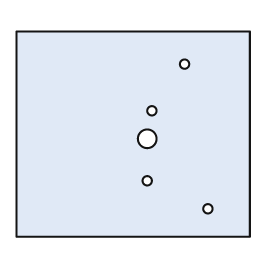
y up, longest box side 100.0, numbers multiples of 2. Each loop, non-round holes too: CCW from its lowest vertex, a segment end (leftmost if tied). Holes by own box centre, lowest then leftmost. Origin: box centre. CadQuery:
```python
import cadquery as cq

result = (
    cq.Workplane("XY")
    .moveTo(-50.0, -44.0)
    .lineTo(50.0, -44.0)
    .lineTo(50.0, 44.0)
    .lineTo(-50.0, 44.0)
    .close()
    .moveTo(32.0, -32.0)
    .circle(2.0)
    .moveTo(6.0, -20.0)
    .circle(2.0)
    .moveTo(6.0, -2.0)
    .circle(4.0)
    .moveTo(8.0, 10.0)
    .circle(2.0)
    .moveTo(22.0, 30.0)
    .circle(2.0)
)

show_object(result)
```